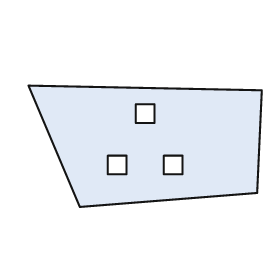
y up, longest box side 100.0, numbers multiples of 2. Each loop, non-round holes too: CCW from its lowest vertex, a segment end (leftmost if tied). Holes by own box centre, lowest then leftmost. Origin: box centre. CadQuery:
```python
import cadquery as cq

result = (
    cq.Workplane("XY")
    .moveTo(-28.0, -26.0)
    .lineTo(48.0, -20.0)
    .lineTo(50.0, 24.0)
    .lineTo(-50.0, 26.0)
    .close()
    .moveTo(-16.0, -12.0)
    .lineTo(-8.0, -12.0)
    .lineTo(-8.0, -4.0)
    .lineTo(-16.0, -4.0)
    .close()
    .moveTo(8.0, -12.0)
    .lineTo(16.0, -12.0)
    .lineTo(16.0, -4.0)
    .lineTo(8.0, -4.0)
    .close()
    .moveTo(-4.0, 10.0)
    .lineTo(4.0, 10.0)
    .lineTo(4.0, 18.0)
    .lineTo(-4.0, 18.0)
    .close()
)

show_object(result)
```